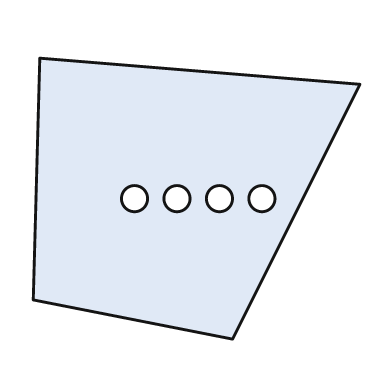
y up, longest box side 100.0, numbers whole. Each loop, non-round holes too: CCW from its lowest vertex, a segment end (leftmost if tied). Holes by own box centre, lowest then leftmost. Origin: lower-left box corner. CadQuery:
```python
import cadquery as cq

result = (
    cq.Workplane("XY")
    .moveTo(61.0, 0.0)
    .lineTo(100.0, 78.0)
    .lineTo(2.0, 86.0)
    .lineTo(0.0, 12.0)
    .close()
    .moveTo(31.0, 43.0)
    .circle(4.0)
    .moveTo(44.0, 43.0)
    .circle(4.0)
    .moveTo(57.0, 43.0)
    .circle(4.0)
    .moveTo(70.0, 43.0)
    .circle(4.0)
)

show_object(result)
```